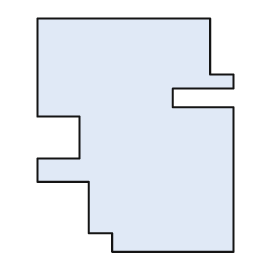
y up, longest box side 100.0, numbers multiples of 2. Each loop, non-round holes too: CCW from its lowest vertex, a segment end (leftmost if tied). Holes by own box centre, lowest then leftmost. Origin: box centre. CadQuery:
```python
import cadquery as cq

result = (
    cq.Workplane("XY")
    .moveTo(-10.0, -50.0)
    .lineTo(42.0, -50.0)
    .lineTo(42.0, 12.0)
    .lineTo(16.0, 12.0)
    .lineTo(16.0, 20.0)
    .lineTo(42.0, 20.0)
    .lineTo(42.0, 26.0)
    .lineTo(32.0, 26.0)
    .lineTo(32.0, 50.0)
    .lineTo(-42.0, 50.0)
    .lineTo(-42.0, 8.0)
    .lineTo(-24.0, 8.0)
    .lineTo(-24.0, -10.0)
    .lineTo(-42.0, -10.0)
    .lineTo(-42.0, -20.0)
    .lineTo(-20.0, -20.0)
    .lineTo(-20.0, -42.0)
    .lineTo(-10.0, -42.0)
    .close()
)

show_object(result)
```